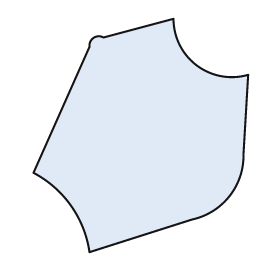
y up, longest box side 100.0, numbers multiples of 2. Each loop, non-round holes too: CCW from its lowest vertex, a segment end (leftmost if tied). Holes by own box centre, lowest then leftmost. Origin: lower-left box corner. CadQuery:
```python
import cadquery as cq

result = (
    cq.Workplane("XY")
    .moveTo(24.0, 0.0)
    .lineTo(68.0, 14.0)
    .threePointArc((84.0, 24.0), (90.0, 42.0))
    .lineTo(92.0, 76.0)
    .threePointArc((70.0, 80.0), (60.0, 100.0))
    .lineTo(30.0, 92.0)
    .threePointArc((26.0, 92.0), (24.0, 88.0))
    .lineTo(0.0, 34.0)
    .threePointArc((16.0, 20.0), (24.0, 0.0))
    .close()
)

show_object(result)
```